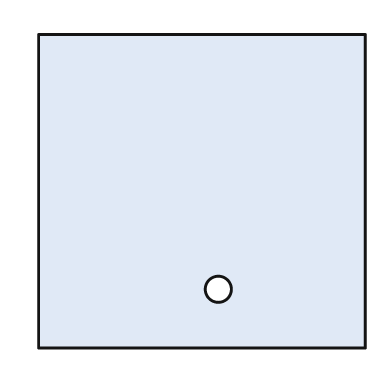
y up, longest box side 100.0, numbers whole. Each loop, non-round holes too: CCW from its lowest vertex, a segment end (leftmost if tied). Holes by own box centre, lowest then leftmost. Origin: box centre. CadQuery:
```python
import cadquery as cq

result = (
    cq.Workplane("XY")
    .moveTo(-50.0, -48.0)
    .lineTo(50.0, -48.0)
    .lineTo(50.0, 48.0)
    .lineTo(-50.0, 48.0)
    .close()
    .moveTo(5.0, -30.0)
    .circle(4.0)
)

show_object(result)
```